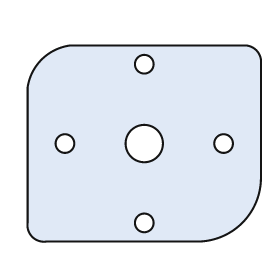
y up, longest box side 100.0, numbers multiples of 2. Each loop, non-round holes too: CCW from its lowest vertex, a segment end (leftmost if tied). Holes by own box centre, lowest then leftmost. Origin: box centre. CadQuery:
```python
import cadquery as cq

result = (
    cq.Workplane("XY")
    .moveTo(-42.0, -42.0)
    .lineTo(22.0, -42.0)
    .threePointArc((42.0, -34.0), (50.0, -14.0))
    .lineTo(50.0, 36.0)
    .threePointArc((48.0, 40.0), (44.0, 42.0))
    .lineTo(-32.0, 42.0)
    .threePointArc((-44.0, 36.0), (-50.0, 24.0))
    .lineTo(-50.0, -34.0)
    .threePointArc((-48.0, -40.0), (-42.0, -42.0))
    .close()
    .moveTo(0.0, -34.0)
    .circle(4.0)
    .moveTo(-34.0, 0.0)
    .circle(4.0)
    .moveTo(0.0, 0.0)
    .circle(8.0)
    .moveTo(34.0, 0.0)
    .circle(4.0)
    .moveTo(0.0, 34.0)
    .circle(4.0)
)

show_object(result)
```